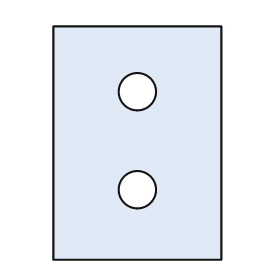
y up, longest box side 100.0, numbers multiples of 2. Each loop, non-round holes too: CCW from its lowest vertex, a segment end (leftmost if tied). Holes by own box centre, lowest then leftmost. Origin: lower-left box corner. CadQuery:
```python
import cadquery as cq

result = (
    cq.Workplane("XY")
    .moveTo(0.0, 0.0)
    .lineTo(72.0, 0.0)
    .lineTo(72.0, 100.0)
    .lineTo(0.0, 100.0)
    .close()
    .moveTo(36.0, 30.0)
    .circle(8.0)
    .moveTo(36.0, 72.0)
    .circle(8.0)
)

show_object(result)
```